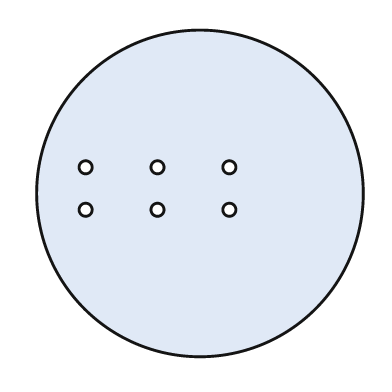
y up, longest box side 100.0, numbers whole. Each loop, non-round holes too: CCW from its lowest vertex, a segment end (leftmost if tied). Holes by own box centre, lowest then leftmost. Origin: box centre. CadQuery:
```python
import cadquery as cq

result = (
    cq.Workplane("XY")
    .moveTo(0.0, 0.0)
    .circle(50.0)
    .moveTo(-35.0, -5.0)
    .circle(2.0)
    .moveTo(-13.0, -5.0)
    .circle(2.0)
    .moveTo(9.0, -5.0)
    .circle(2.0)
    .moveTo(-35.0, 8.0)
    .circle(2.0)
    .moveTo(-13.0, 8.0)
    .circle(2.0)
    .moveTo(9.0, 8.0)
    .circle(2.0)
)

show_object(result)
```